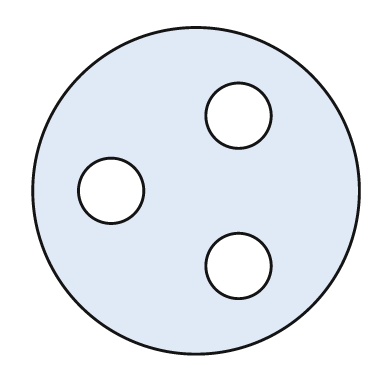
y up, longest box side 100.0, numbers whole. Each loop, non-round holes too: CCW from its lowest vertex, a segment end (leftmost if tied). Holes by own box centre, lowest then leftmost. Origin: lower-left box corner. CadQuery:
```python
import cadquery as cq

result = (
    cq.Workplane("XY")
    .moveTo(50.0, 50.0)
    .circle(50.0)
    .moveTo(63.0, 27.0)
    .circle(10.0)
    .moveTo(24.0, 50.0)
    .circle(10.0)
    .moveTo(63.0, 73.0)
    .circle(10.0)
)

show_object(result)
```